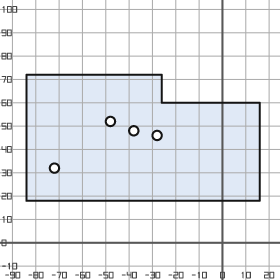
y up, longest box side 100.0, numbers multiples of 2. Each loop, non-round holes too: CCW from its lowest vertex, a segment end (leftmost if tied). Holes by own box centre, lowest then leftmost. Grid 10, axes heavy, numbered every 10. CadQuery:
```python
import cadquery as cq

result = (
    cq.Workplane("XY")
    .moveTo(-84.0, 18.0)
    .lineTo(16.0, 18.0)
    .lineTo(16.0, 60.0)
    .lineTo(-26.0, 60.0)
    .lineTo(-26.0, 72.0)
    .lineTo(-84.0, 72.0)
    .close()
    .moveTo(-72.0, 32.0)
    .circle(2.0)
    .moveTo(-28.0, 46.0)
    .circle(2.0)
    .moveTo(-38.0, 48.0)
    .circle(2.0)
    .moveTo(-48.0, 52.0)
    .circle(2.0)
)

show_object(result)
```